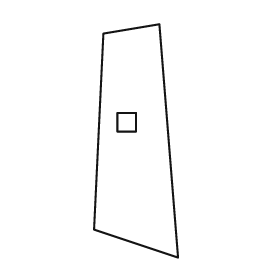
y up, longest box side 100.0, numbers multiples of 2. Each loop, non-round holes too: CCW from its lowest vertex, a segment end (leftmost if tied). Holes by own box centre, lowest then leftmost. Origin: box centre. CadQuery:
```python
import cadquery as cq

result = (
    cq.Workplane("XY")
    .moveTo(18.0, -50.0)
    .lineTo(10.0, 50.0)
    .lineTo(-14.0, 46.0)
    .lineTo(-18.0, -38.0)
    .close()
    .moveTo(-8.0, 4.0)
    .lineTo(0.0, 4.0)
    .lineTo(0.0, 12.0)
    .lineTo(-8.0, 12.0)
    .close()
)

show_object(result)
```